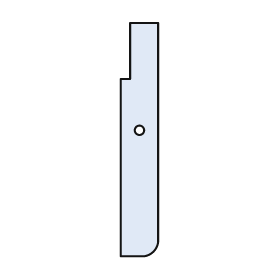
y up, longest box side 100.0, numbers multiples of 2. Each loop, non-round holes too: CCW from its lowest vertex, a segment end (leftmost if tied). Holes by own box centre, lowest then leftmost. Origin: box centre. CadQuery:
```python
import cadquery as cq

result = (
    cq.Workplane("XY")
    .moveTo(-8.0, -50.0)
    .lineTo(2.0, -50.0)
    .threePointArc((6.0, -48.0), (8.0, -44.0))
    .lineTo(8.0, 50.0)
    .lineTo(-4.0, 50.0)
    .lineTo(-4.0, 26.0)
    .lineTo(-8.0, 26.0)
    .close()
    .moveTo(0.0, 4.0)
    .circle(2.0)
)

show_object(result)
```